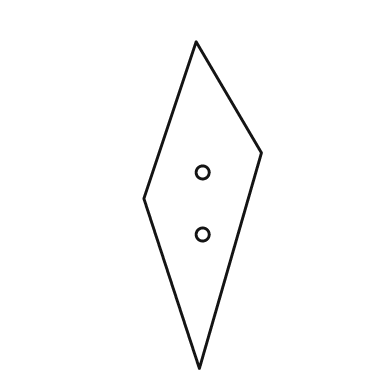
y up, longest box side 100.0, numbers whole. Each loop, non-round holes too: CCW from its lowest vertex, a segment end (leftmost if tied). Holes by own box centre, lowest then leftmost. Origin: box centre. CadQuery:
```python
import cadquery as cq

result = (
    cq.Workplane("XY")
    .moveTo(-1.0, -50.0)
    .lineTo(18.0, 16.0)
    .lineTo(-2.0, 50.0)
    .lineTo(-18.0, 2.0)
    .close()
    .moveTo(0.0, -9.0)
    .circle(2.0)
    .moveTo(0.0, 10.0)
    .circle(2.0)
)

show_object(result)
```